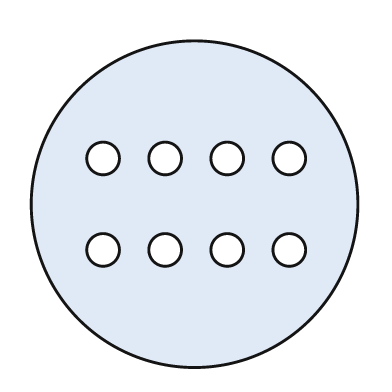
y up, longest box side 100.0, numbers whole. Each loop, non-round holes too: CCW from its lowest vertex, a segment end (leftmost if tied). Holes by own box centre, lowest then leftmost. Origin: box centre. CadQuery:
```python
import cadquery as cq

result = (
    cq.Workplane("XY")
    .moveTo(0.0, 0.0)
    .circle(50.0)
    .moveTo(-28.0, -14.0)
    .circle(5.0)
    .moveTo(-9.0, -14.0)
    .circle(5.0)
    .moveTo(10.0, -14.0)
    .circle(5.0)
    .moveTo(29.0, -14.0)
    .circle(5.0)
    .moveTo(-28.0, 14.0)
    .circle(5.0)
    .moveTo(-9.0, 14.0)
    .circle(5.0)
    .moveTo(10.0, 14.0)
    .circle(5.0)
    .moveTo(29.0, 14.0)
    .circle(5.0)
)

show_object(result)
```